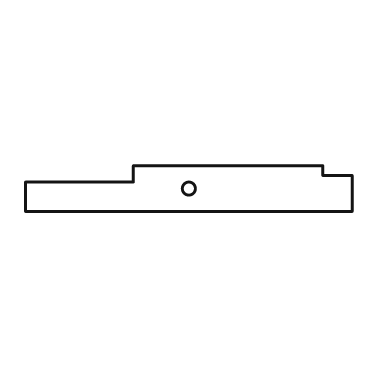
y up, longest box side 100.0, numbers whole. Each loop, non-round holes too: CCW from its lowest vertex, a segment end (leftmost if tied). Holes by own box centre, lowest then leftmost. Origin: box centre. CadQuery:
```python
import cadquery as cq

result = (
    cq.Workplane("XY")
    .moveTo(-50.0, -7.0)
    .lineTo(50.0, -7.0)
    .lineTo(50.0, 4.0)
    .lineTo(41.0, 4.0)
    .lineTo(41.0, 7.0)
    .lineTo(-17.0, 7.0)
    .lineTo(-17.0, 2.0)
    .lineTo(-50.0, 2.0)
    .close()
    .moveTo(0.0, 0.0)
    .circle(2.0)
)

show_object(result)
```